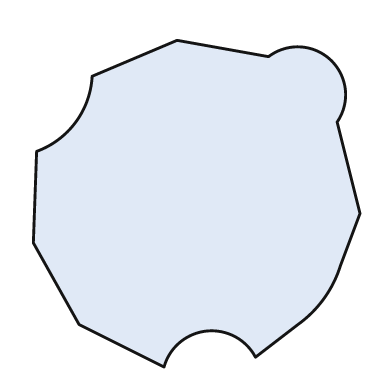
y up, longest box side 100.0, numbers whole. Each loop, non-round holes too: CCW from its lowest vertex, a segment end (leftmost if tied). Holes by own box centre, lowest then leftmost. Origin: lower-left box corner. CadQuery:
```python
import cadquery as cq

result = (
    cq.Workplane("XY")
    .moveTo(40.0, 0.0)
    .threePointArc((53.0, 11.0), (68.0, 3.0))
    .lineTo(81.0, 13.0)
    .threePointArc((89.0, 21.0), (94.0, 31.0))
    .lineTo(100.0, 47.0)
    .lineTo(93.0, 75.0)
    .threePointArc((91.0, 94.0), (72.0, 95.0))
    .lineTo(44.0, 100.0)
    .lineTo(18.0, 89.0)
    .threePointArc((13.0, 75.0), (1.0, 66.0))
    .lineTo(0.0, 38.0)
    .lineTo(14.0, 13.0)
    .close()
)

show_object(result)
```